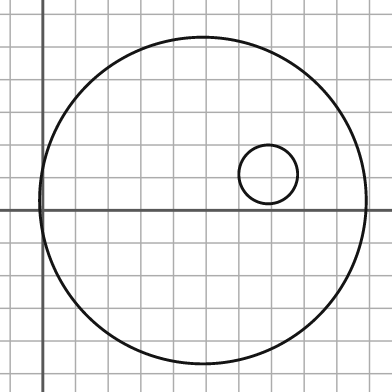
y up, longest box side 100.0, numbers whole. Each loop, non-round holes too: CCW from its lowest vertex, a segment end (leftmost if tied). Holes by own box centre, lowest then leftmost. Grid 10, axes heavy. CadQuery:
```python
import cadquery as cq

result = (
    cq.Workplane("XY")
    .moveTo(49.0, 3.0)
    .circle(50.0)
    .moveTo(69.0, 11.0)
    .circle(9.0)
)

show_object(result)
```